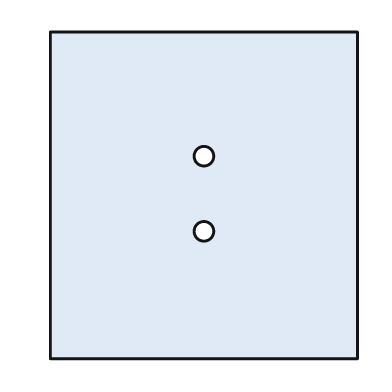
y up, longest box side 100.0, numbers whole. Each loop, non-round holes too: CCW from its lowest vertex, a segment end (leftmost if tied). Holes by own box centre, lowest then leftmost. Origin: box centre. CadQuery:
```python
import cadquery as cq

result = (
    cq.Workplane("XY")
    .moveTo(-47.0, -50.0)
    .lineTo(47.0, -50.0)
    .lineTo(47.0, 50.0)
    .lineTo(-47.0, 50.0)
    .close()
    .moveTo(0.0, -11.0)
    .circle(3.0)
    .moveTo(0.0, 12.0)
    .circle(3.0)
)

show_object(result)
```